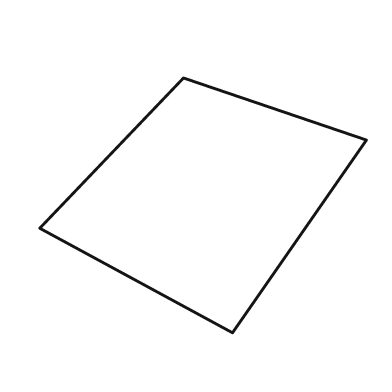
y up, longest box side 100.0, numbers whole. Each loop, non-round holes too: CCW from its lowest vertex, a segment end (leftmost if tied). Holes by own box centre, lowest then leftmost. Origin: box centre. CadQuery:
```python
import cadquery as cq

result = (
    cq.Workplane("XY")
    .moveTo(9.0, -39.0)
    .lineTo(50.0, 20.0)
    .lineTo(-6.0, 39.0)
    .lineTo(-50.0, -7.0)
    .close()
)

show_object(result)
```